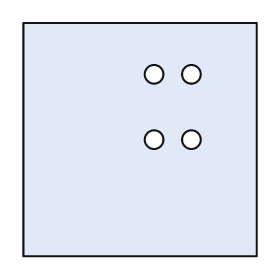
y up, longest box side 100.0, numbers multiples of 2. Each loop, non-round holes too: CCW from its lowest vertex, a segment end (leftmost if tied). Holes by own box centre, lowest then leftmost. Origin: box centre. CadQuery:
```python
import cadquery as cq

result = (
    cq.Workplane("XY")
    .moveTo(-50.0, -50.0)
    .lineTo(50.0, -50.0)
    .lineTo(50.0, 50.0)
    .lineTo(-50.0, 50.0)
    .close()
    .moveTo(6.0, 0.0)
    .circle(4.0)
    .moveTo(22.0, 0.0)
    .circle(4.0)
    .moveTo(6.0, 28.0)
    .circle(4.0)
    .moveTo(22.0, 28.0)
    .circle(4.0)
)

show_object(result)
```